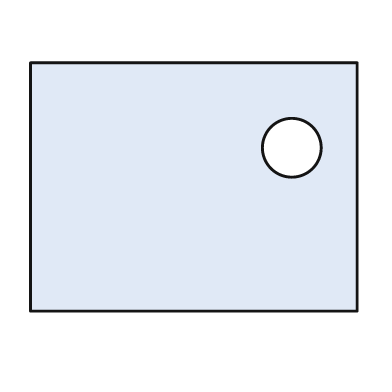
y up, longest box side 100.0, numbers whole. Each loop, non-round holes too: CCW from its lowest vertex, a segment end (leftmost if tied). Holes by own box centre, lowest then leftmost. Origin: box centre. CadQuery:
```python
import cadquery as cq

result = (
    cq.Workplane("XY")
    .moveTo(-50.0, -38.0)
    .lineTo(50.0, -38.0)
    .lineTo(50.0, 38.0)
    .lineTo(-50.0, 38.0)
    .close()
    .moveTo(30.0, 12.0)
    .circle(9.0)
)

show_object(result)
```